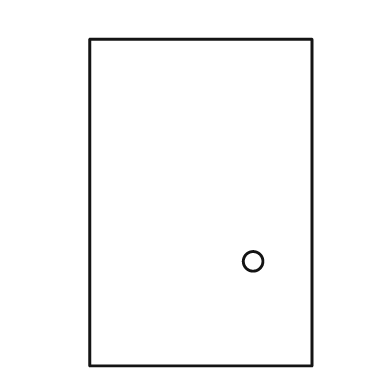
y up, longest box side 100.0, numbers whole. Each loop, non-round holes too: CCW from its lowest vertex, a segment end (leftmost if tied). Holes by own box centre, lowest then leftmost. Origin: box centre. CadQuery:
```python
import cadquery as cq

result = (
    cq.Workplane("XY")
    .moveTo(-34.0, -50.0)
    .lineTo(34.0, -50.0)
    .lineTo(34.0, 50.0)
    .lineTo(-34.0, 50.0)
    .close()
    .moveTo(16.0, -18.0)
    .circle(3.0)
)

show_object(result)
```